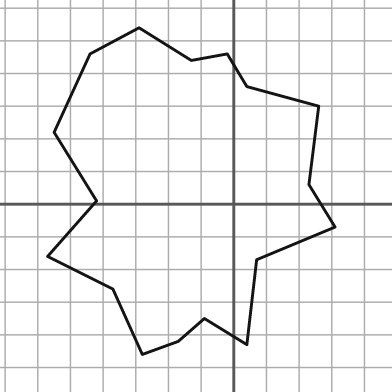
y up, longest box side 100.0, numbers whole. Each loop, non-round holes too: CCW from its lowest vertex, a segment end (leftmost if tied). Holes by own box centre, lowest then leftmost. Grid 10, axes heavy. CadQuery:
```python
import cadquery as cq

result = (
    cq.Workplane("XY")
    .moveTo(-28.0, -46.0)
    .lineTo(-17.0, -42.0)
    .lineTo(-9.0, -35.0)
    .lineTo(4.0, -43.0)
    .lineTo(7.0, -17.0)
    .lineTo(31.0, -7.0)
    .lineTo(23.0, 6.0)
    .lineTo(26.0, 30.0)
    .lineTo(4.0, 36.0)
    .lineTo(-2.0, 46.0)
    .lineTo(-13.0, 44.0)
    .lineTo(-29.0, 54.0)
    .lineTo(-44.0, 46.0)
    .lineTo(-55.0, 22.0)
    .lineTo(-42.0, 1.0)
    .lineTo(-57.0, -16.0)
    .lineTo(-37.0, -26.0)
    .close()
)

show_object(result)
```